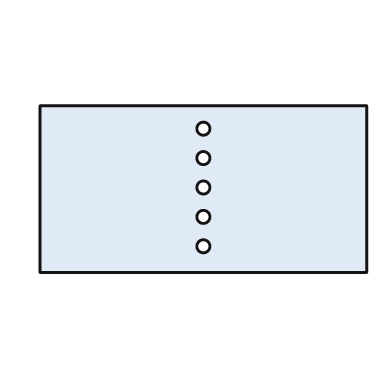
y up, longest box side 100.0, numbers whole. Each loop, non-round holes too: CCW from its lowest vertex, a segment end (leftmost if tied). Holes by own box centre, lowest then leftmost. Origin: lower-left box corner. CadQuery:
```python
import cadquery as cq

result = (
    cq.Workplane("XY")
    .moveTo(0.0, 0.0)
    .lineTo(100.0, 0.0)
    .lineTo(100.0, 51.0)
    .lineTo(0.0, 51.0)
    .close()
    .moveTo(50.0, 8.0)
    .circle(2.0)
    .moveTo(50.0, 17.0)
    .circle(2.0)
    .moveTo(50.0, 26.0)
    .circle(2.0)
    .moveTo(50.0, 35.0)
    .circle(2.0)
    .moveTo(50.0, 44.0)
    .circle(2.0)
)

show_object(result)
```